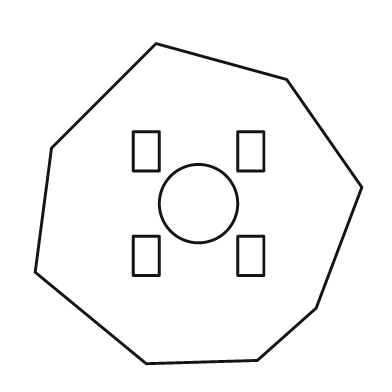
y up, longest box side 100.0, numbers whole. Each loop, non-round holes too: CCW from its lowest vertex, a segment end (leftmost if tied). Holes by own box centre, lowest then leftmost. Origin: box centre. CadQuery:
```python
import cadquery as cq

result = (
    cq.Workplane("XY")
    .moveTo(-16.0, -49.0)
    .lineTo(18.0, -48.0)
    .lineTo(36.0, -32.0)
    .lineTo(50.0, 5.0)
    .lineTo(27.0, 38.0)
    .lineTo(-13.0, 49.0)
    .lineTo(-45.0, 17.0)
    .lineTo(-50.0, -21.0)
    .close()
    .moveTo(-20.0, -22.0)
    .lineTo(-12.0, -22.0)
    .lineTo(-12.0, -10.0)
    .lineTo(-20.0, -10.0)
    .close()
    .moveTo(12.0, -22.0)
    .lineTo(20.0, -22.0)
    .lineTo(20.0, -10.0)
    .lineTo(12.0, -10.0)
    .close()
    .moveTo(0.0, 0.0)
    .circle(12.0)
    .moveTo(-20.0, 10.0)
    .lineTo(-12.0, 10.0)
    .lineTo(-12.0, 22.0)
    .lineTo(-20.0, 22.0)
    .close()
    .moveTo(12.0, 10.0)
    .lineTo(20.0, 10.0)
    .lineTo(20.0, 22.0)
    .lineTo(12.0, 22.0)
    .close()
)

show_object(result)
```